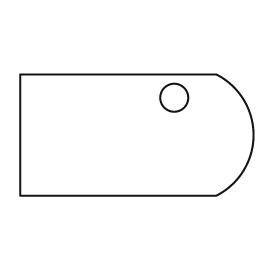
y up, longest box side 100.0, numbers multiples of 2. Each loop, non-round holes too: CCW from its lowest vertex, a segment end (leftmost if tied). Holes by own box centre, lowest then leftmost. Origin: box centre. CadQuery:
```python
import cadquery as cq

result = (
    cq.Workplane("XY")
    .moveTo(-50.0, -26.0)
    .lineTo(34.0, -26.0)
    .threePointArc((50.0, 0.0), (34.0, 26.0))
    .lineTo(-50.0, 26.0)
    .close()
    .moveTo(16.0, 16.0)
    .circle(6.0)
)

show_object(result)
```